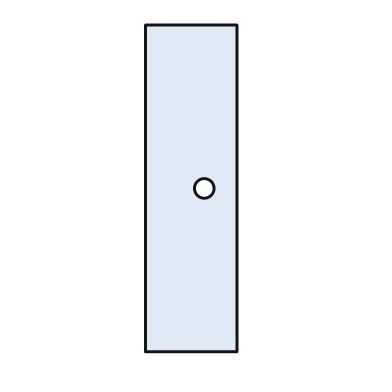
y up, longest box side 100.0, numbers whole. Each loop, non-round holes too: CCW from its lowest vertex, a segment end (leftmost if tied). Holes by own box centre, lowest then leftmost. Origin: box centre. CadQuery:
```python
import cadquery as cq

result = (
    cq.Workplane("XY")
    .moveTo(-14.0, -50.0)
    .lineTo(14.0, -50.0)
    .lineTo(14.0, 50.0)
    .lineTo(-14.0, 50.0)
    .close()
    .moveTo(4.0, 0.0)
    .circle(3.0)
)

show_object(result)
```